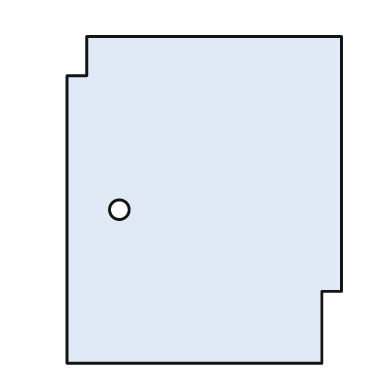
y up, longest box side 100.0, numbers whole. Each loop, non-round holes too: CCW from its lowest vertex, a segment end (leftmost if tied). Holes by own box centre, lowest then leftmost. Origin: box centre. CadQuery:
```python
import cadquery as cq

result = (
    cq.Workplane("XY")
    .moveTo(-42.0, -50.0)
    .lineTo(36.0, -50.0)
    .lineTo(36.0, -28.0)
    .lineTo(42.0, -28.0)
    .lineTo(42.0, 50.0)
    .lineTo(-36.0, 50.0)
    .lineTo(-36.0, 38.0)
    .lineTo(-42.0, 38.0)
    .close()
    .moveTo(-26.0, -3.0)
    .circle(3.0)
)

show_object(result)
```